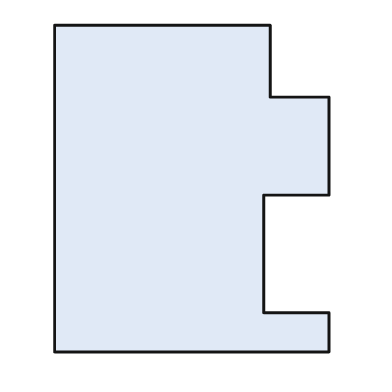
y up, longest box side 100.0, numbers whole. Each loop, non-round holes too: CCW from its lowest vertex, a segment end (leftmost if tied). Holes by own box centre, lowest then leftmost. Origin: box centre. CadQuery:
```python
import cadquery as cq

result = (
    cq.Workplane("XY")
    .moveTo(-42.0, -50.0)
    .lineTo(42.0, -50.0)
    .lineTo(42.0, -38.0)
    .lineTo(22.0, -38.0)
    .lineTo(22.0, -2.0)
    .lineTo(42.0, -2.0)
    .lineTo(42.0, 28.0)
    .lineTo(24.0, 28.0)
    .lineTo(24.0, 50.0)
    .lineTo(-42.0, 50.0)
    .close()
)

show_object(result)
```